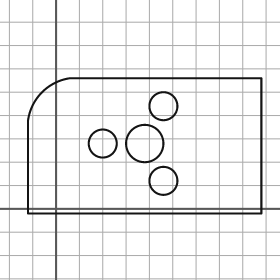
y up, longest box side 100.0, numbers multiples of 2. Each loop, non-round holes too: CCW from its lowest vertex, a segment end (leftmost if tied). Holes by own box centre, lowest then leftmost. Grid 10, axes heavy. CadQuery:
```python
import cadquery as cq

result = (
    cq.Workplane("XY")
    .moveTo(-12.0, -2.0)
    .lineTo(88.0, -2.0)
    .lineTo(88.0, 56.0)
    .lineTo(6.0, 56.0)
    .threePointArc((-6.0, 50.0), (-12.0, 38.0))
    .close()
    .moveTo(46.0, 12.0)
    .circle(6.0)
    .moveTo(20.0, 28.0)
    .circle(6.0)
    .moveTo(38.0, 28.0)
    .circle(8.0)
    .moveTo(46.0, 44.0)
    .circle(6.0)
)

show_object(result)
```